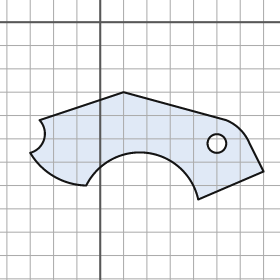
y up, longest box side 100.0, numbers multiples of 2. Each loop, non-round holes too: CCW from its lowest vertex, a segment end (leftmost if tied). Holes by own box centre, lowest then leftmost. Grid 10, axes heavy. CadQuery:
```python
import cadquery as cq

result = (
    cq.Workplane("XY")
    .moveTo(42.0, -76.0)
    .lineTo(70.0, -64.0)
    .lineTo(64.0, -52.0)
    .threePointArc((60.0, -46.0), (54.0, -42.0))
    .lineTo(10.0, -30.0)
    .lineTo(-26.0, -42.0)
    .threePointArc((-24.0, -50.0), (-30.0, -56.0))
    .threePointArc((-20.0, -66.0), (-6.0, -70.0))
    .threePointArc((20.0, -56.0), (42.0, -76.0))
    .close()
    .moveTo(50.0, -52.0)
    .circle(4.0)
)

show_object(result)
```